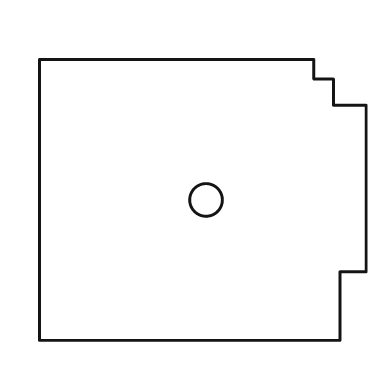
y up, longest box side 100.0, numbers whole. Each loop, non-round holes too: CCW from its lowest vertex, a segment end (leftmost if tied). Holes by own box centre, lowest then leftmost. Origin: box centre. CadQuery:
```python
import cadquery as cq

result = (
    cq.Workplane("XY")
    .moveTo(-50.0, -43.0)
    .lineTo(42.0, -43.0)
    .lineTo(42.0, -22.0)
    .lineTo(50.0, -22.0)
    .lineTo(50.0, 29.0)
    .lineTo(40.0, 29.0)
    .lineTo(40.0, 37.0)
    .lineTo(34.0, 37.0)
    .lineTo(34.0, 43.0)
    .lineTo(-50.0, 43.0)
    .close()
    .moveTo(1.0, 0.0)
    .circle(5.0)
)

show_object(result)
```